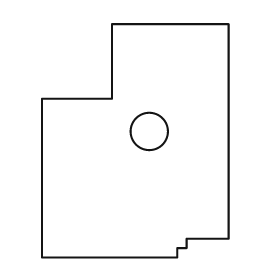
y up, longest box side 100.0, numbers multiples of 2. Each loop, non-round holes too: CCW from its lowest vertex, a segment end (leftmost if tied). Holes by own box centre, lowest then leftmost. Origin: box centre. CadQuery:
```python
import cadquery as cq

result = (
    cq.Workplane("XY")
    .moveTo(-40.0, -50.0)
    .lineTo(18.0, -50.0)
    .lineTo(18.0, -46.0)
    .lineTo(22.0, -46.0)
    .lineTo(22.0, -42.0)
    .lineTo(40.0, -42.0)
    .lineTo(40.0, 50.0)
    .lineTo(-10.0, 50.0)
    .lineTo(-10.0, 18.0)
    .lineTo(-40.0, 18.0)
    .close()
    .moveTo(6.0, 4.0)
    .circle(8.0)
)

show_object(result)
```